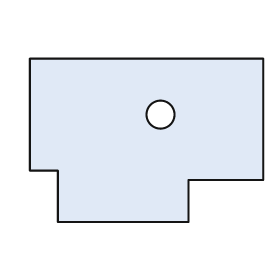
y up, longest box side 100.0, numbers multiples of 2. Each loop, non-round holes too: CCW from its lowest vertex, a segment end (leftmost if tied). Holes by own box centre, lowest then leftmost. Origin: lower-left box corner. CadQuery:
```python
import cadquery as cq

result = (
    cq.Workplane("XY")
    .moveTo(12.0, 0.0)
    .lineTo(68.0, 0.0)
    .lineTo(68.0, 18.0)
    .lineTo(100.0, 18.0)
    .lineTo(100.0, 70.0)
    .lineTo(0.0, 70.0)
    .lineTo(0.0, 22.0)
    .lineTo(12.0, 22.0)
    .close()
    .moveTo(56.0, 46.0)
    .circle(6.0)
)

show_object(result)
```